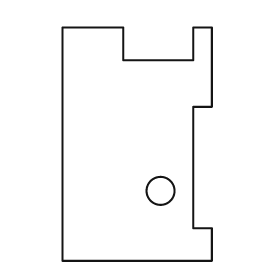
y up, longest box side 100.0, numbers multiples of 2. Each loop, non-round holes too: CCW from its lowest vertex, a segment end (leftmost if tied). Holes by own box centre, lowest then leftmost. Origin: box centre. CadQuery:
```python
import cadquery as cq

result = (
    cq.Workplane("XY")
    .moveTo(-32.0, -50.0)
    .lineTo(32.0, -50.0)
    .lineTo(32.0, -36.0)
    .lineTo(24.0, -36.0)
    .lineTo(24.0, 16.0)
    .lineTo(32.0, 16.0)
    .lineTo(32.0, 50.0)
    .lineTo(24.0, 50.0)
    .lineTo(24.0, 36.0)
    .lineTo(-6.0, 36.0)
    .lineTo(-6.0, 50.0)
    .lineTo(-32.0, 50.0)
    .close()
    .moveTo(10.0, -20.0)
    .circle(6.0)
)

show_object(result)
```